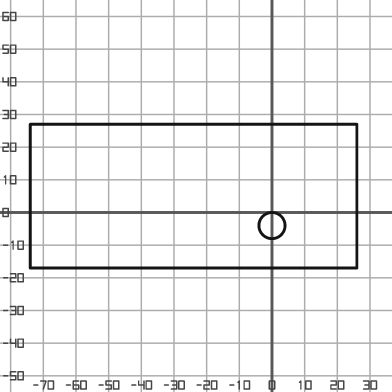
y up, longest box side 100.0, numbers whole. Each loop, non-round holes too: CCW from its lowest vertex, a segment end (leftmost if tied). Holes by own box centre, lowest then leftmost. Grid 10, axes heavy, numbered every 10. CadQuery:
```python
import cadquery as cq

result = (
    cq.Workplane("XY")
    .moveTo(-74.0, -17.0)
    .lineTo(26.0, -17.0)
    .lineTo(26.0, 27.0)
    .lineTo(-74.0, 27.0)
    .close()
    .moveTo(0.0, -4.0)
    .circle(4.0)
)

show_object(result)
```